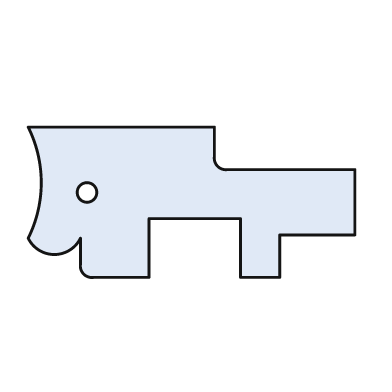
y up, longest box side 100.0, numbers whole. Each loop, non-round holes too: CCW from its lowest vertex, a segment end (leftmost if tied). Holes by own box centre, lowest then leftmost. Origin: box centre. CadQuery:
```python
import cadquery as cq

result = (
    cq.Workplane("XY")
    .moveTo(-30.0, -23.0)
    .lineTo(-13.0, -23.0)
    .lineTo(-13.0, -5.0)
    .lineTo(15.0, -5.0)
    .lineTo(15.0, -23.0)
    .lineTo(27.0, -23.0)
    .lineTo(27.0, -10.0)
    .lineTo(50.0, -10.0)
    .lineTo(50.0, 10.0)
    .lineTo(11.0, 10.0)
    .threePointArc((8.0, 11.0), (7.0, 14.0))
    .lineTo(7.0, 23.0)
    .lineTo(-50.0, 23.0)
    .threePointArc((-46.0, 6.0), (-50.0, -11.0))
    .threePointArc((-42.0, -16.0), (-34.0, -11.0))
    .lineTo(-34.0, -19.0)
    .threePointArc((-33.0, -22.0), (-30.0, -23.0))
    .close()
    .moveTo(-32.0, 3.0)
    .circle(3.0)
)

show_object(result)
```